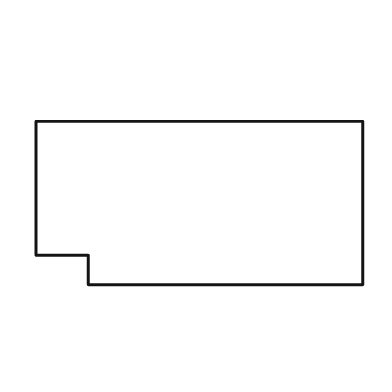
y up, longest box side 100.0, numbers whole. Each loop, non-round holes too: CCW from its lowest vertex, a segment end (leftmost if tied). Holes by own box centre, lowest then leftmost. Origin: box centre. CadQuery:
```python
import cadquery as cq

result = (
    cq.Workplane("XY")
    .moveTo(-34.0, -25.0)
    .lineTo(50.0, -25.0)
    .lineTo(50.0, 25.0)
    .lineTo(-50.0, 25.0)
    .lineTo(-50.0, -16.0)
    .lineTo(-34.0, -16.0)
    .close()
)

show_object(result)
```